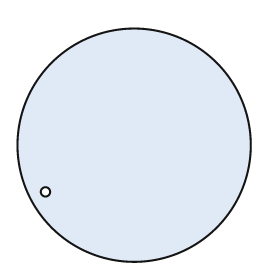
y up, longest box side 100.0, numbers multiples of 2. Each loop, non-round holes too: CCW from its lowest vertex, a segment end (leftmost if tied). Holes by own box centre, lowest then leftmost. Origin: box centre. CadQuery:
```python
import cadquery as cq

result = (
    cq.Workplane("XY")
    .moveTo(0.0, 0.0)
    .circle(50.0)
    .moveTo(-38.0, -20.0)
    .circle(2.0)
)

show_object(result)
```